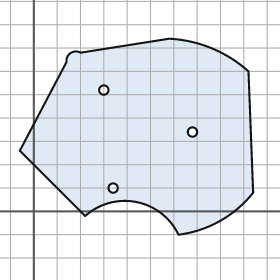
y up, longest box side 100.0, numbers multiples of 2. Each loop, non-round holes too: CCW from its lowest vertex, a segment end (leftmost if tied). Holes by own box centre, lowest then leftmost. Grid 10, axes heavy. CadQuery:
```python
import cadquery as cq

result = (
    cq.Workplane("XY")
    .moveTo(62.0, -10.0)
    .threePointArc((80.0, -4.0), (94.0, 8.0))
    .lineTo(92.0, 60.0)
    .threePointArc((76.0, 70.0), (58.0, 74.0))
    .lineTo(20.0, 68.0)
    .threePointArc((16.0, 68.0), (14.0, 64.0))
    .lineTo(-6.0, 26.0)
    .lineTo(22.0, -2.0)
    .threePointArc((44.0, 4.0), (62.0, -10.0))
    .close()
    .moveTo(34.0, 10.0)
    .circle(2.0)
    .moveTo(68.0, 34.0)
    .circle(2.0)
    .moveTo(30.0, 52.0)
    .circle(2.0)
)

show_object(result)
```